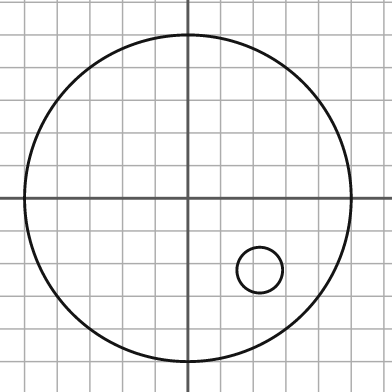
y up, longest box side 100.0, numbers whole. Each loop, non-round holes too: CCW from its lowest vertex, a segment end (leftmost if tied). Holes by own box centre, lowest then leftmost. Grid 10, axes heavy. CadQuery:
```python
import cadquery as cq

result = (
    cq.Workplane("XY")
    .moveTo(0.0, 0.0)
    .circle(50.0)
    .moveTo(22.0, -22.0)
    .circle(7.0)
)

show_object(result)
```